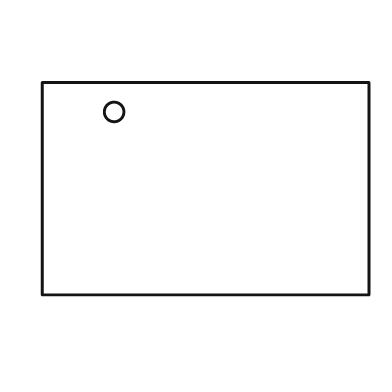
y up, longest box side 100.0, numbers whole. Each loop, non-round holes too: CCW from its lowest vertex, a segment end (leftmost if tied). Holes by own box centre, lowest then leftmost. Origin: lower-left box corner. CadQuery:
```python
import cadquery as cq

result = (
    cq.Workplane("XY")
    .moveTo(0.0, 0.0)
    .lineTo(100.0, 0.0)
    .lineTo(100.0, 65.0)
    .lineTo(0.0, 65.0)
    .close()
    .moveTo(22.0, 56.0)
    .circle(3.0)
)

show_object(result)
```